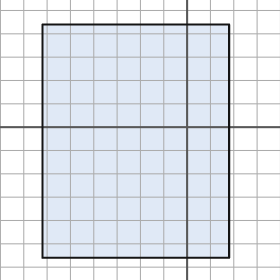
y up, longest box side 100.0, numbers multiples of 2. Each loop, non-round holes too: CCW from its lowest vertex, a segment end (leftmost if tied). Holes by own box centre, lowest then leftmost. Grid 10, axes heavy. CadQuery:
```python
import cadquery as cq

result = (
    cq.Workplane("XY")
    .moveTo(-62.0, -56.0)
    .lineTo(18.0, -56.0)
    .lineTo(18.0, 44.0)
    .lineTo(-62.0, 44.0)
    .close()
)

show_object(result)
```